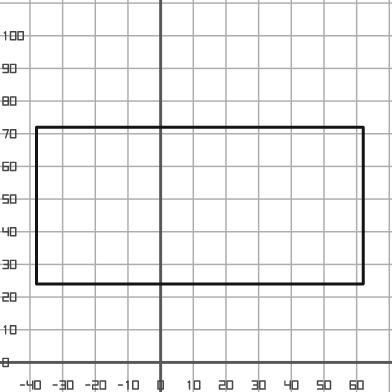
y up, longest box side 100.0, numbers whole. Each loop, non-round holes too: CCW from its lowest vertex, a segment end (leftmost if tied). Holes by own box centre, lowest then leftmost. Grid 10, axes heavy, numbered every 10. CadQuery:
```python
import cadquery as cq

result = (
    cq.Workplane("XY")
    .moveTo(-38.0, 24.0)
    .lineTo(62.0, 24.0)
    .lineTo(62.0, 72.0)
    .lineTo(-38.0, 72.0)
    .close()
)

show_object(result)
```